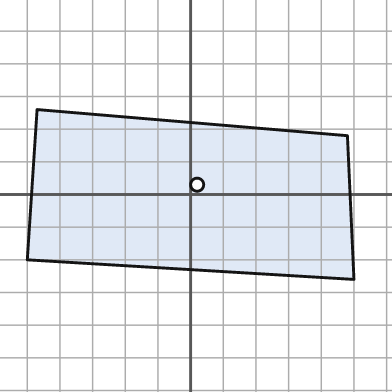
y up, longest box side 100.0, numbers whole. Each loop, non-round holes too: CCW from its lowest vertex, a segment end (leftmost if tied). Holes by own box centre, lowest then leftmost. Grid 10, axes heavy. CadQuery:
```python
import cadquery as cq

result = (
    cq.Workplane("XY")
    .moveTo(50.0, -26.0)
    .lineTo(48.0, 18.0)
    .lineTo(-47.0, 26.0)
    .lineTo(-50.0, -20.0)
    .close()
    .moveTo(2.0, 3.0)
    .circle(2.0)
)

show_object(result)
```